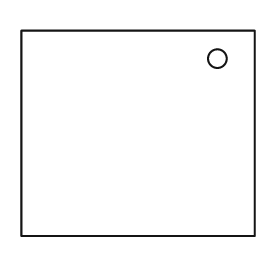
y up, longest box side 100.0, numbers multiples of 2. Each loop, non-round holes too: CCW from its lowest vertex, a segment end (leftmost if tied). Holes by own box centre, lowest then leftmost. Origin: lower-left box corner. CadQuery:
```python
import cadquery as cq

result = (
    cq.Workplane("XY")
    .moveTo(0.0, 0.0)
    .lineTo(100.0, 0.0)
    .lineTo(100.0, 88.0)
    .lineTo(0.0, 88.0)
    .close()
    .moveTo(84.0, 76.0)
    .circle(4.0)
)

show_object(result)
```